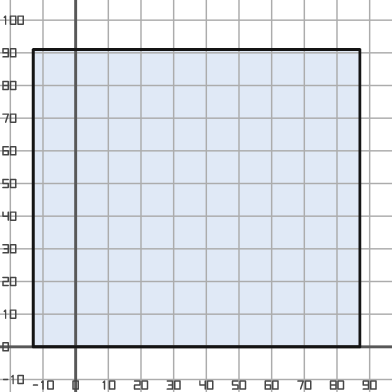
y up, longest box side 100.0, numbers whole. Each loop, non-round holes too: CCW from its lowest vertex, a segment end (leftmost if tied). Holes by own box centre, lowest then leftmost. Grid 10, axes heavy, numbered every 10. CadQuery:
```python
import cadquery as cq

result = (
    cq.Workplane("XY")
    .moveTo(-13.0, 0.0)
    .lineTo(87.0, 0.0)
    .lineTo(87.0, 91.0)
    .lineTo(-13.0, 91.0)
    .close()
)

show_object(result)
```